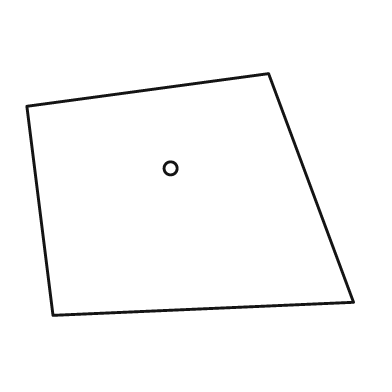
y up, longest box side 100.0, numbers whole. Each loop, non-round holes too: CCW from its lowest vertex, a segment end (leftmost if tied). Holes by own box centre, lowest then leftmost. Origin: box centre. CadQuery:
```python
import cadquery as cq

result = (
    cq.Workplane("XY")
    .moveTo(-42.0, -37.0)
    .lineTo(50.0, -33.0)
    .lineTo(24.0, 37.0)
    .lineTo(-50.0, 27.0)
    .close()
    .moveTo(-6.0, 8.0)
    .circle(2.0)
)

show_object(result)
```